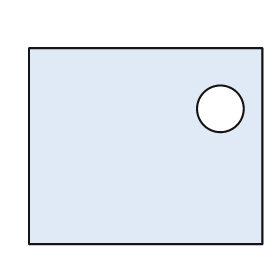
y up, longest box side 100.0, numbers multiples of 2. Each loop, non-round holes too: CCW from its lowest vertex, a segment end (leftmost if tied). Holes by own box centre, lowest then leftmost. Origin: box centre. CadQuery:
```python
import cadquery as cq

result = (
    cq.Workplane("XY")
    .moveTo(-50.0, -42.0)
    .lineTo(50.0, -42.0)
    .lineTo(50.0, 42.0)
    .lineTo(-50.0, 42.0)
    .close()
    .moveTo(32.0, 16.0)
    .circle(10.0)
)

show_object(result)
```